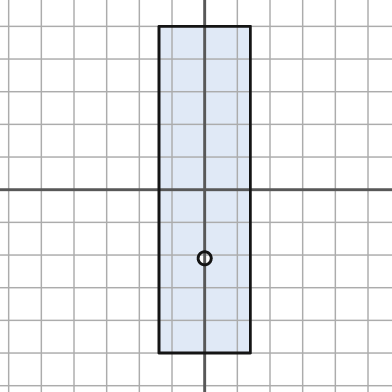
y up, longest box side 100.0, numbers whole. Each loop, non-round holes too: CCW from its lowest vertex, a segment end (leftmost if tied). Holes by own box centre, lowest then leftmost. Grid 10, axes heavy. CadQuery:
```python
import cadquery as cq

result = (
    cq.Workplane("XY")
    .moveTo(-14.0, -50.0)
    .lineTo(14.0, -50.0)
    .lineTo(14.0, 50.0)
    .lineTo(-14.0, 50.0)
    .close()
    .moveTo(0.0, -21.0)
    .circle(2.0)
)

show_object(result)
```